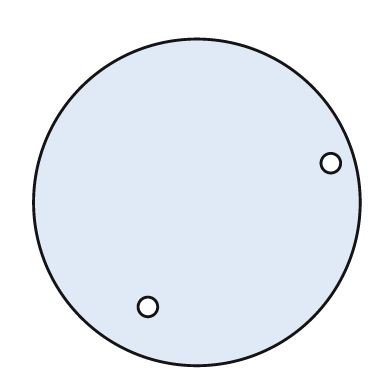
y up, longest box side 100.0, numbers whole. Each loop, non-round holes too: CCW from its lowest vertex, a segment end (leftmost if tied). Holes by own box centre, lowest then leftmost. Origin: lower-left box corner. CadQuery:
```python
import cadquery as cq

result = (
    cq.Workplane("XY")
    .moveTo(50.0, 50.0)
    .circle(50.0)
    .moveTo(35.0, 18.0)
    .circle(3.0)
    .moveTo(91.0, 62.0)
    .circle(3.0)
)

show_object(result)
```